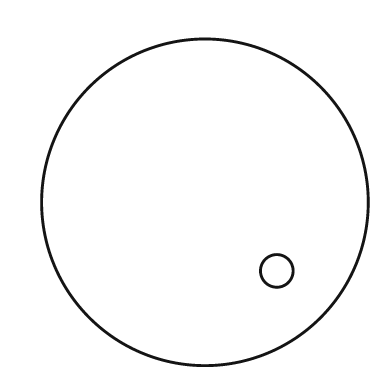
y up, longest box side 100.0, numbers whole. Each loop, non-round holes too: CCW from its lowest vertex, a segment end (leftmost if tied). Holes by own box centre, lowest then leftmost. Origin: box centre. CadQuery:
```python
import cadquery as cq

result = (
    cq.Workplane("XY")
    .moveTo(0.0, 0.0)
    .circle(50.0)
    .moveTo(22.0, -21.0)
    .circle(5.0)
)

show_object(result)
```